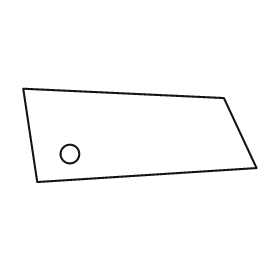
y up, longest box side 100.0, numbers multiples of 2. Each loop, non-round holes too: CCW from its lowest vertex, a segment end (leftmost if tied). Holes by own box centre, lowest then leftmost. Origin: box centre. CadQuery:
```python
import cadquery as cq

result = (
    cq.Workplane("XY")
    .moveTo(-44.0, -20.0)
    .lineTo(50.0, -14.0)
    .lineTo(36.0, 16.0)
    .lineTo(-50.0, 20.0)
    .close()
    .moveTo(-30.0, -8.0)
    .circle(4.0)
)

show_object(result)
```